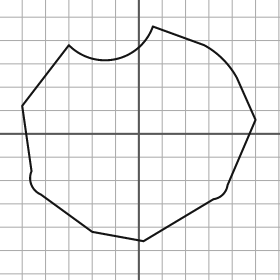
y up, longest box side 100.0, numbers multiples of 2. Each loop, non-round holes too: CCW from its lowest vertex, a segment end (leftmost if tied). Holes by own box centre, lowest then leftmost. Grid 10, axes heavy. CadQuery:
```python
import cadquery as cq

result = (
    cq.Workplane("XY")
    .moveTo(2.0, -46.0)
    .lineTo(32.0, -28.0)
    .threePointArc((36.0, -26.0), (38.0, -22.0))
    .lineTo(50.0, 6.0)
    .lineTo(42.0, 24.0)
    .threePointArc((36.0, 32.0), (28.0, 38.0))
    .lineTo(6.0, 46.0)
    .threePointArc((-10.0, 32.0), (-30.0, 38.0))
    .lineTo(-50.0, 12.0)
    .lineTo(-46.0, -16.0)
    .threePointArc((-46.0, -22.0), (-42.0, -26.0))
    .lineTo(-20.0, -42.0)
    .close()
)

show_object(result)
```